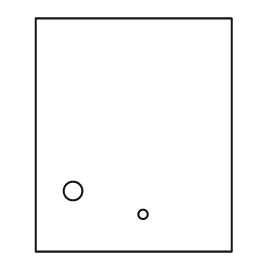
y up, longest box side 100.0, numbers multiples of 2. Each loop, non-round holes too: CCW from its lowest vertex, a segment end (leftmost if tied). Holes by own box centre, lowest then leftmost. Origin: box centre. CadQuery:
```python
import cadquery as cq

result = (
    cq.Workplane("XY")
    .moveTo(-42.0, -50.0)
    .lineTo(42.0, -50.0)
    .lineTo(42.0, 50.0)
    .lineTo(-42.0, 50.0)
    .close()
    .moveTo(4.0, -34.0)
    .circle(2.0)
    .moveTo(-26.0, -24.0)
    .circle(4.0)
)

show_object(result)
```